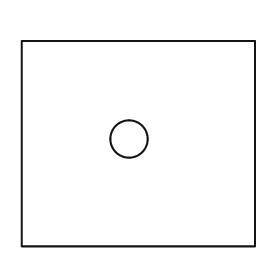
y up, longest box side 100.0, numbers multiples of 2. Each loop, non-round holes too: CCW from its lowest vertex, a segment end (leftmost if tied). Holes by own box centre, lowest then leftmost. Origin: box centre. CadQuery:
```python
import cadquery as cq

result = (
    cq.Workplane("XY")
    .moveTo(-50.0, -44.0)
    .lineTo(50.0, -44.0)
    .lineTo(50.0, 44.0)
    .lineTo(-50.0, 44.0)
    .close()
    .moveTo(-4.0, 2.0)
    .circle(8.0)
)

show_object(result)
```